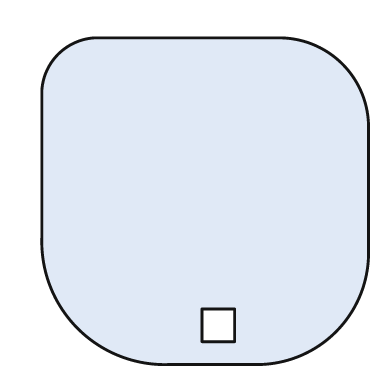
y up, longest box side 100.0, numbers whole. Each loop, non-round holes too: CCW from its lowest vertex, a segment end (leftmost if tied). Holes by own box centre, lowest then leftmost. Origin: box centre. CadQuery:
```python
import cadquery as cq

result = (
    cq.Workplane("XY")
    .moveTo(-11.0, -50.0)
    .lineTo(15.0, -50.0)
    .threePointArc((40.0, -40.0), (50.0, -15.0))
    .lineTo(50.0, 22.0)
    .threePointArc((42.0, 42.0), (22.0, 50.0))
    .lineTo(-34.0, 50.0)
    .threePointArc((-45.0, 45.0), (-50.0, 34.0))
    .lineTo(-50.0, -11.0)
    .threePointArc((-39.0, -39.0), (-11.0, -50.0))
    .close()
    .moveTo(-1.0, -43.0)
    .lineTo(9.0, -43.0)
    .lineTo(9.0, -33.0)
    .lineTo(-1.0, -33.0)
    .close()
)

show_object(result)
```